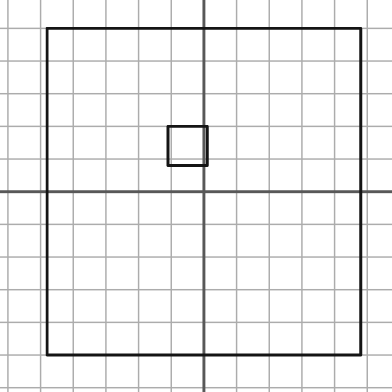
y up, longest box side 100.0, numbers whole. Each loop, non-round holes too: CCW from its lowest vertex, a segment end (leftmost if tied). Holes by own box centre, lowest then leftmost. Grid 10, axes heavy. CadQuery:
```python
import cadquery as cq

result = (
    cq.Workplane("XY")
    .moveTo(-48.0, -50.0)
    .lineTo(48.0, -50.0)
    .lineTo(48.0, 50.0)
    .lineTo(-48.0, 50.0)
    .close()
    .moveTo(-11.0, 8.0)
    .lineTo(1.0, 8.0)
    .lineTo(1.0, 20.0)
    .lineTo(-11.0, 20.0)
    .close()
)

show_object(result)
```